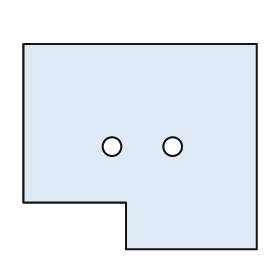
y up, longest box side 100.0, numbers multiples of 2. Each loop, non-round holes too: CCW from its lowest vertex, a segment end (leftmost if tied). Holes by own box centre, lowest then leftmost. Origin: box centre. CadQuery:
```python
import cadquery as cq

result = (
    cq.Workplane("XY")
    .moveTo(-6.0, -44.0)
    .lineTo(50.0, -44.0)
    .lineTo(50.0, 44.0)
    .lineTo(-50.0, 44.0)
    .lineTo(-50.0, -24.0)
    .lineTo(-6.0, -24.0)
    .close()
    .moveTo(-12.0, 0.0)
    .circle(4.0)
    .moveTo(14.0, 0.0)
    .circle(4.0)
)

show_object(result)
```